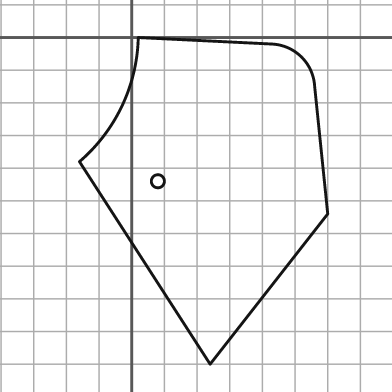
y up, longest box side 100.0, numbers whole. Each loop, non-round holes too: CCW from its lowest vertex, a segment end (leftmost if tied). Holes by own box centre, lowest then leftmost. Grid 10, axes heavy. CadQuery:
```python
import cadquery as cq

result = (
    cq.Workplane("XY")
    .moveTo(24.0, -100.0)
    .lineTo(60.0, -54.0)
    .lineTo(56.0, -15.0)
    .threePointArc((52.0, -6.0), (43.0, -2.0))
    .lineTo(2.0, 0.0)
    .threePointArc((-3.0, -21.0), (-16.0, -38.0))
    .close()
    .moveTo(8.0, -44.0)
    .circle(2.0)
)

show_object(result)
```